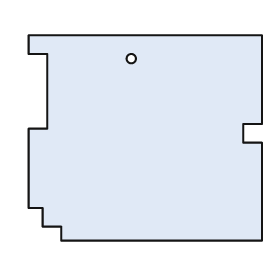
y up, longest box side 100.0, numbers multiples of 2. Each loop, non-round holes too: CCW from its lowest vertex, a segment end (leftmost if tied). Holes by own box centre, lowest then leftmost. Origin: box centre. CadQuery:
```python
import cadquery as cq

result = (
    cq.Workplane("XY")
    .moveTo(-36.0, -44.0)
    .lineTo(50.0, -44.0)
    .lineTo(50.0, -2.0)
    .lineTo(42.0, -2.0)
    .lineTo(42.0, 6.0)
    .lineTo(50.0, 6.0)
    .lineTo(50.0, 44.0)
    .lineTo(-50.0, 44.0)
    .lineTo(-50.0, 36.0)
    .lineTo(-42.0, 36.0)
    .lineTo(-42.0, 4.0)
    .lineTo(-50.0, 4.0)
    .lineTo(-50.0, -30.0)
    .lineTo(-44.0, -30.0)
    .lineTo(-44.0, -38.0)
    .lineTo(-36.0, -38.0)
    .close()
    .moveTo(-6.0, 34.0)
    .circle(2.0)
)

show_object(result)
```